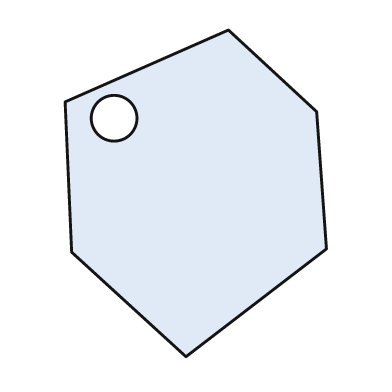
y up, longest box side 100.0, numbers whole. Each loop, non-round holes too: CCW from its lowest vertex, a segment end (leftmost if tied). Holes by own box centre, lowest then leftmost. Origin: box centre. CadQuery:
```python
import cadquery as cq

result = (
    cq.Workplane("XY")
    .moveTo(-3.0, -50.0)
    .lineTo(40.0, -17.0)
    .lineTo(37.0, 25.0)
    .lineTo(10.0, 50.0)
    .lineTo(-40.0, 28.0)
    .lineTo(-38.0, -18.0)
    .close()
    .moveTo(-25.0, 23.0)
    .circle(7.0)
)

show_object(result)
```